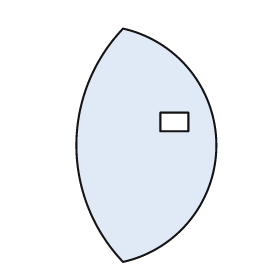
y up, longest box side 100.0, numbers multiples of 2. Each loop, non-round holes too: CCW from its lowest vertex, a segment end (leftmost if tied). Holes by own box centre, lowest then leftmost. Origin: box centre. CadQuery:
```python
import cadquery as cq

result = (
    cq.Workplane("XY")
    .moveTo(-10.0, -50.0)
    .threePointArc((30.0, 0.0), (-10.0, 50.0))
    .threePointArc((-30.0, 0.0), (-10.0, -50.0))
    .close()
    .moveTo(6.0, 6.0)
    .lineTo(18.0, 6.0)
    .lineTo(18.0, 14.0)
    .lineTo(6.0, 14.0)
    .close()
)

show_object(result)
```